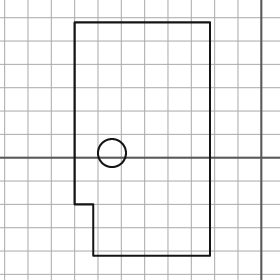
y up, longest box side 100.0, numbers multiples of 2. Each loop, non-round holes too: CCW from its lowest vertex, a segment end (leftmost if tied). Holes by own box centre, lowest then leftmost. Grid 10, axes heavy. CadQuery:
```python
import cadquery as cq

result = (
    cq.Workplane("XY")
    .moveTo(-72.0, -42.0)
    .lineTo(-22.0, -42.0)
    .lineTo(-22.0, 58.0)
    .lineTo(-80.0, 58.0)
    .lineTo(-80.0, -20.0)
    .lineTo(-72.0, -20.0)
    .close()
    .moveTo(-64.0, 2.0)
    .circle(6.0)
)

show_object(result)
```